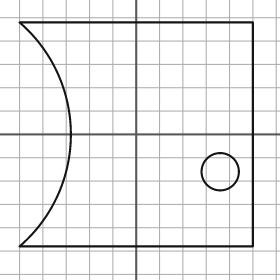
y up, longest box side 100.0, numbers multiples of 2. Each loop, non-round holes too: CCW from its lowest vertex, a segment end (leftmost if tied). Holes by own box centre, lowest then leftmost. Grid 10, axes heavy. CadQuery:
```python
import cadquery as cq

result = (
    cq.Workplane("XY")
    .moveTo(-50.0, -48.0)
    .lineTo(50.0, -48.0)
    .lineTo(50.0, 48.0)
    .lineTo(-50.0, 48.0)
    .threePointArc((-28.0, 0.0), (-50.0, -48.0))
    .close()
    .moveTo(36.0, -16.0)
    .circle(8.0)
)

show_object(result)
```